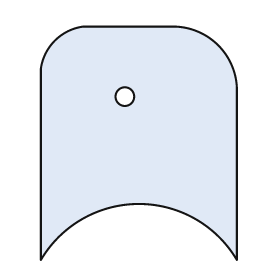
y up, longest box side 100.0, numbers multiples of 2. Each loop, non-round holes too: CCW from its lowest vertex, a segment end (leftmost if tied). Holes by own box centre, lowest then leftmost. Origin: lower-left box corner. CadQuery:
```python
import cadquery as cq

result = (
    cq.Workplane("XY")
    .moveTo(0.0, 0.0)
    .threePointArc((42.0, 24.0), (84.0, 0.0))
    .lineTo(84.0, 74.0)
    .threePointArc((76.0, 92.0), (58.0, 100.0))
    .lineTo(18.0, 100.0)
    .threePointArc((6.0, 94.0), (0.0, 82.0))
    .close()
    .moveTo(36.0, 70.0)
    .circle(4.0)
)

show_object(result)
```